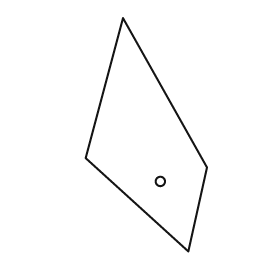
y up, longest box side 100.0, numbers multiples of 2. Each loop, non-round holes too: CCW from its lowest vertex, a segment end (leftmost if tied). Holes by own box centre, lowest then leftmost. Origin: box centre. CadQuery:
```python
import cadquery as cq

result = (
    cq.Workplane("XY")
    .moveTo(18.0, -50.0)
    .lineTo(26.0, -14.0)
    .lineTo(-10.0, 50.0)
    .lineTo(-26.0, -10.0)
    .close()
    .moveTo(6.0, -20.0)
    .circle(2.0)
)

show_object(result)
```